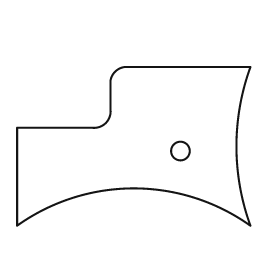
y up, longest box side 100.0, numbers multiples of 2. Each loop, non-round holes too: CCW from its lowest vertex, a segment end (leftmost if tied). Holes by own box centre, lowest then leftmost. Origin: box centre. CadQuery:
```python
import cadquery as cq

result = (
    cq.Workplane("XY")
    .moveTo(-50.0, -34.0)
    .threePointArc((0.0, -18.0), (50.0, -34.0))
    .threePointArc((44.0, 0.0), (50.0, 34.0))
    .lineTo(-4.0, 34.0)
    .threePointArc((-8.0, 32.0), (-10.0, 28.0))
    .lineTo(-10.0, 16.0)
    .threePointArc((-12.0, 10.0), (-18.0, 8.0))
    .lineTo(-50.0, 8.0)
    .close()
    .moveTo(20.0, -2.0)
    .circle(4.0)
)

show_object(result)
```